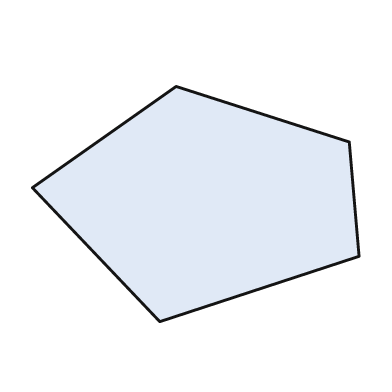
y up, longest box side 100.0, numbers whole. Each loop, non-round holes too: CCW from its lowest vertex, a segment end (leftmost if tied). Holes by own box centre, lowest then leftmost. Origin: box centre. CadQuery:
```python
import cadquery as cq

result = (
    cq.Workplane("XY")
    .moveTo(-11.0, -36.0)
    .lineTo(50.0, -16.0)
    .lineTo(47.0, 19.0)
    .lineTo(-6.0, 36.0)
    .lineTo(-50.0, 5.0)
    .close()
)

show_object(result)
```